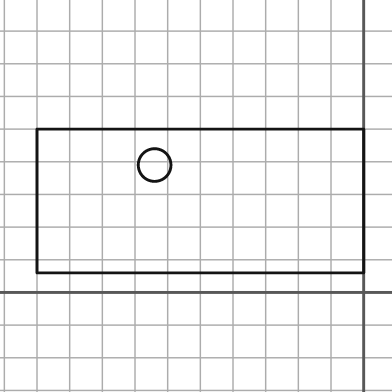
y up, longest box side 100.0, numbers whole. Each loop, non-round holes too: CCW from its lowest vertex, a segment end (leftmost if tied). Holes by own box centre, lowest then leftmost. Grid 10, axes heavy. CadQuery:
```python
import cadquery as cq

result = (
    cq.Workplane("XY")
    .moveTo(-100.0, 6.0)
    .lineTo(0.0, 6.0)
    .lineTo(0.0, 50.0)
    .lineTo(-100.0, 50.0)
    .close()
    .moveTo(-64.0, 39.0)
    .circle(5.0)
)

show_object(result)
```